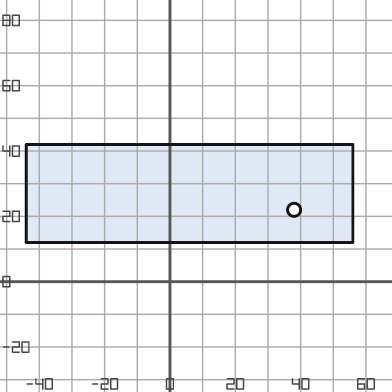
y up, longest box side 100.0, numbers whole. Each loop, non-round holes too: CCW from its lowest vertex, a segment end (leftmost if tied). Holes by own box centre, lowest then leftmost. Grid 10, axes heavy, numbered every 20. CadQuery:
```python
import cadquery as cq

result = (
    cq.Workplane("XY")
    .moveTo(-44.0, 12.0)
    .lineTo(56.0, 12.0)
    .lineTo(56.0, 42.0)
    .lineTo(-44.0, 42.0)
    .close()
    .moveTo(38.0, 22.0)
    .circle(2.0)
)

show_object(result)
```